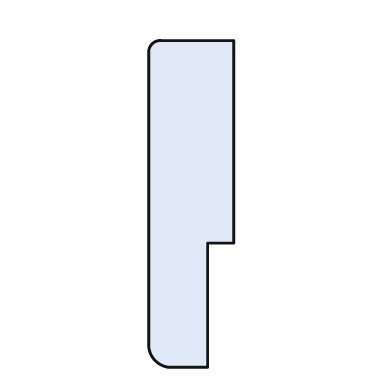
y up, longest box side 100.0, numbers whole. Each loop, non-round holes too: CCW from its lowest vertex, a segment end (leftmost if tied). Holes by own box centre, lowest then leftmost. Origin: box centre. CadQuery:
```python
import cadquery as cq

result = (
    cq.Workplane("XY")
    .moveTo(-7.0, -50.0)
    .lineTo(5.0, -50.0)
    .lineTo(5.0, -12.0)
    .lineTo(13.0, -12.0)
    .lineTo(13.0, 50.0)
    .lineTo(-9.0, 50.0)
    .threePointArc((-12.0, 49.0), (-13.0, 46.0))
    .lineTo(-13.0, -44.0)
    .threePointArc((-11.0, -48.0), (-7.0, -50.0))
    .close()
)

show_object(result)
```